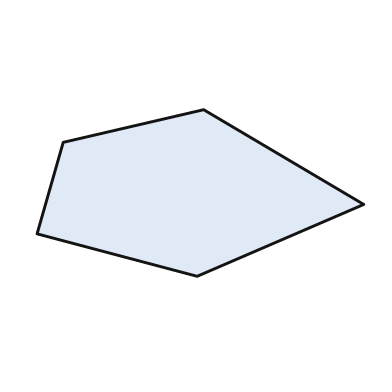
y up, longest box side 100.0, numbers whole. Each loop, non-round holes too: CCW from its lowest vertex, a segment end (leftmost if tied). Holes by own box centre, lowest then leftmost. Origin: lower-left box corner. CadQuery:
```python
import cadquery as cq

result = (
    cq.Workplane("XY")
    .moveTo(49.0, 0.0)
    .lineTo(100.0, 22.0)
    .lineTo(51.0, 51.0)
    .lineTo(8.0, 41.0)
    .lineTo(0.0, 13.0)
    .close()
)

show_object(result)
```